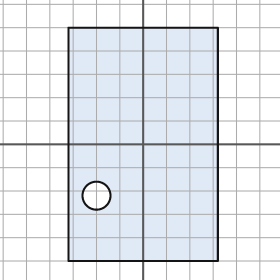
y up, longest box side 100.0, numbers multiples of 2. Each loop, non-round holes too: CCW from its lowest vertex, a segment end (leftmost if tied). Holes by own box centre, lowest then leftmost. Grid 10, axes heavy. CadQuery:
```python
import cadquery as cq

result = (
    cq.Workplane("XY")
    .moveTo(-32.0, -50.0)
    .lineTo(32.0, -50.0)
    .lineTo(32.0, 50.0)
    .lineTo(-32.0, 50.0)
    .close()
    .moveTo(-20.0, -22.0)
    .circle(6.0)
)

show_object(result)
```